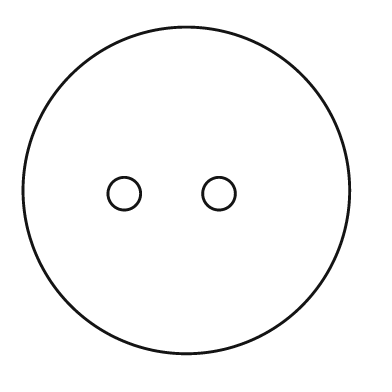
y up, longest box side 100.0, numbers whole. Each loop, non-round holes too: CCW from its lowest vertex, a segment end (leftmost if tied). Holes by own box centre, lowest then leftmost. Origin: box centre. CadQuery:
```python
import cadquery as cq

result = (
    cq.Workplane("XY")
    .moveTo(0.0, 0.0)
    .circle(50.0)
    .moveTo(-19.0, -1.0)
    .circle(5.0)
    .moveTo(10.0, -1.0)
    .circle(5.0)
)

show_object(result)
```